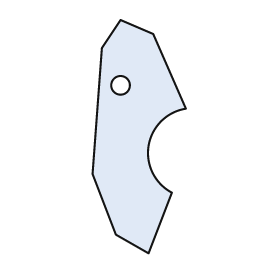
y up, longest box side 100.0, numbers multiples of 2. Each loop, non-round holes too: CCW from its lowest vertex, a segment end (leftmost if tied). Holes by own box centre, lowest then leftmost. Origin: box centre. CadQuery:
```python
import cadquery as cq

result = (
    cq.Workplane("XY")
    .moveTo(4.0, -50.0)
    .lineTo(14.0, -24.0)
    .threePointArc((4.0, -4.0), (20.0, 12.0))
    .lineTo(6.0, 44.0)
    .lineTo(-8.0, 50.0)
    .lineTo(-16.0, 38.0)
    .lineTo(-20.0, -16.0)
    .lineTo(-10.0, -42.0)
    .close()
    .moveTo(-8.0, 22.0)
    .circle(4.0)
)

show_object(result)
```